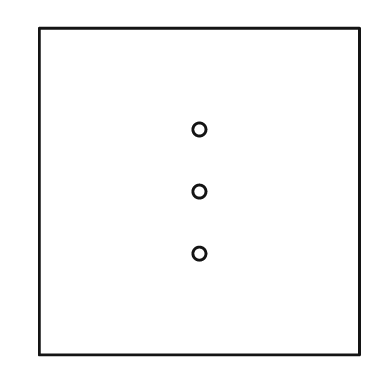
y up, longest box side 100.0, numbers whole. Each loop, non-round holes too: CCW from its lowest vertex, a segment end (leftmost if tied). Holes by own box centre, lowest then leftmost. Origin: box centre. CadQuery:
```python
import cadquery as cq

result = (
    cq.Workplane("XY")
    .moveTo(-49.0, -50.0)
    .lineTo(49.0, -50.0)
    .lineTo(49.0, 50.0)
    .lineTo(-49.0, 50.0)
    .close()
    .moveTo(0.0, -19.0)
    .circle(2.0)
    .moveTo(0.0, 0.0)
    .circle(2.0)
    .moveTo(0.0, 19.0)
    .circle(2.0)
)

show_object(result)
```